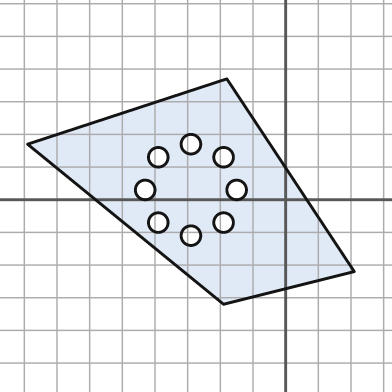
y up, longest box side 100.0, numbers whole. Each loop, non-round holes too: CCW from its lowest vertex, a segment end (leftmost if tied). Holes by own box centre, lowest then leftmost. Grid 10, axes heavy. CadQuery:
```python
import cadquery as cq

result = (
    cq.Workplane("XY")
    .moveTo(-19.0, -32.0)
    .lineTo(21.0, -22.0)
    .lineTo(-18.0, 37.0)
    .lineTo(-79.0, 17.0)
    .close()
    .moveTo(-29.0, -11.0)
    .circle(3.0)
    .moveTo(-39.0, -7.0)
    .circle(3.0)
    .moveTo(-19.0, -7.0)
    .circle(3.0)
    .moveTo(-43.0, 3.0)
    .circle(3.0)
    .moveTo(-15.0, 3.0)
    .circle(3.0)
    .moveTo(-39.0, 13.0)
    .circle(3.0)
    .moveTo(-19.0, 13.0)
    .circle(3.0)
    .moveTo(-29.0, 17.0)
    .circle(3.0)
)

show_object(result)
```